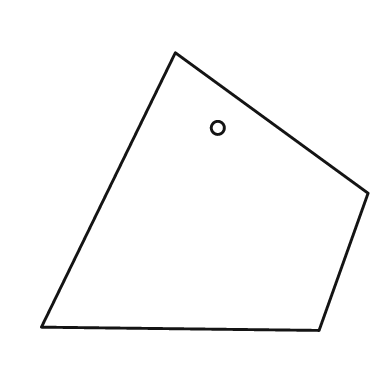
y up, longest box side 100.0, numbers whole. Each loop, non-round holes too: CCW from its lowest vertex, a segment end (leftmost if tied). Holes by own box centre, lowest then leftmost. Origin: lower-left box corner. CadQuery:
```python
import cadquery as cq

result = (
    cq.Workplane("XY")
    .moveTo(85.0, 0.0)
    .lineTo(100.0, 42.0)
    .lineTo(41.0, 85.0)
    .lineTo(0.0, 1.0)
    .close()
    .moveTo(54.0, 62.0)
    .circle(2.0)
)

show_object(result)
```